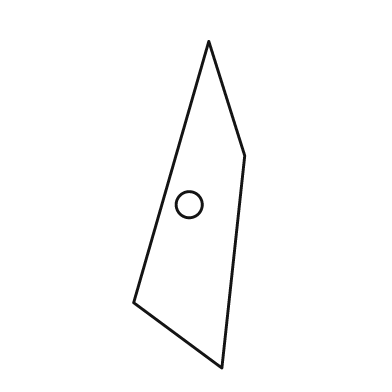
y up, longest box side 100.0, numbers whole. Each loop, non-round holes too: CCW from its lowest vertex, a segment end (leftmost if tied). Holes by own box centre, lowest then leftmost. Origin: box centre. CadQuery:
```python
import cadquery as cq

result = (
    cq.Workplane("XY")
    .moveTo(10.0, -50.0)
    .lineTo(17.0, 15.0)
    .lineTo(6.0, 50.0)
    .lineTo(-17.0, -30.0)
    .close()
    .moveTo(0.0, 0.0)
    .circle(4.0)
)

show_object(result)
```